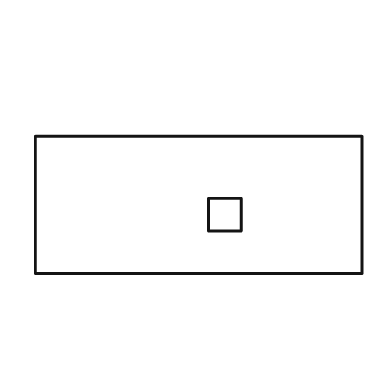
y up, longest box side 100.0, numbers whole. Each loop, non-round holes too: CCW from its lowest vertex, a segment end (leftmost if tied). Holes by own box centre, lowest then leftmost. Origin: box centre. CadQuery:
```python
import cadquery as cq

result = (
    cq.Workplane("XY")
    .moveTo(-50.0, -21.0)
    .lineTo(50.0, -21.0)
    .lineTo(50.0, 21.0)
    .lineTo(-50.0, 21.0)
    .close()
    .moveTo(3.0, -8.0)
    .lineTo(13.0, -8.0)
    .lineTo(13.0, 2.0)
    .lineTo(3.0, 2.0)
    .close()
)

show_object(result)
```